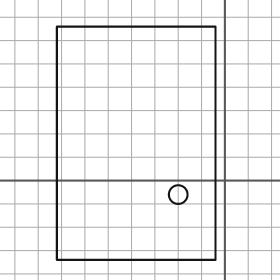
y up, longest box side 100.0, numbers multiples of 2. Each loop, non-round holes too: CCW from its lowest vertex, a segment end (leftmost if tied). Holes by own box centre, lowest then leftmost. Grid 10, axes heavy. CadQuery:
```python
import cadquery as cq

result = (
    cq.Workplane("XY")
    .moveTo(-72.0, -34.0)
    .lineTo(-4.0, -34.0)
    .lineTo(-4.0, 66.0)
    .lineTo(-72.0, 66.0)
    .close()
    .moveTo(-20.0, -6.0)
    .circle(4.0)
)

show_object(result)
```